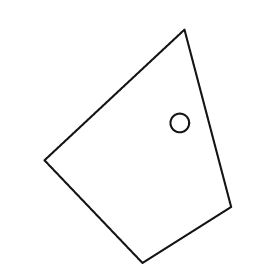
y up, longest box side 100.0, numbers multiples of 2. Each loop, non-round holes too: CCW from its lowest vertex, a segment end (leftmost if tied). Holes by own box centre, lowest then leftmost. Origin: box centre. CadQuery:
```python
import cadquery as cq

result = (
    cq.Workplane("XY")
    .moveTo(2.0, -50.0)
    .lineTo(40.0, -26.0)
    .lineTo(20.0, 50.0)
    .lineTo(-40.0, -6.0)
    .close()
    .moveTo(18.0, 10.0)
    .circle(4.0)
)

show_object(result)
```